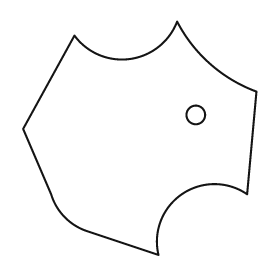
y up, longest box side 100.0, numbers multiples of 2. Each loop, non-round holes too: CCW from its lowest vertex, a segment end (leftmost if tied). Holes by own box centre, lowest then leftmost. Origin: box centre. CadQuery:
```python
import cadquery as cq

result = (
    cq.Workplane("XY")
    .moveTo(8.0, -50.0)
    .threePointArc((18.0, -24.0), (46.0, -24.0))
    .lineTo(50.0, 20.0)
    .threePointArc((30.0, 32.0), (16.0, 50.0))
    .threePointArc((-4.0, 34.0), (-28.0, 44.0))
    .lineTo(-50.0, 4.0)
    .lineTo(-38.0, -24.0)
    .threePointArc((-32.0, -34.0), (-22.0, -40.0))
    .close()
    .moveTo(24.0, 10.0)
    .circle(4.0)
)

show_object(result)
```